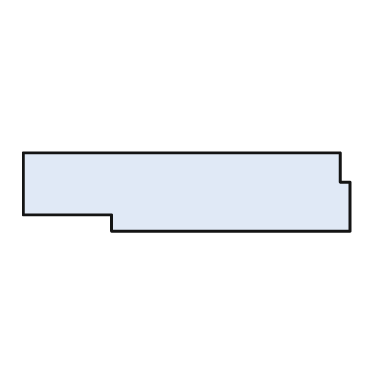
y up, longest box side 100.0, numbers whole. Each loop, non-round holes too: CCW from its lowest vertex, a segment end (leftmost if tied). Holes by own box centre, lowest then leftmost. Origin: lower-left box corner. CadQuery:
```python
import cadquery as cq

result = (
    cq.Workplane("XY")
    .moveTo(27.0, 0.0)
    .lineTo(100.0, 0.0)
    .lineTo(100.0, 15.0)
    .lineTo(97.0, 15.0)
    .lineTo(97.0, 24.0)
    .lineTo(0.0, 24.0)
    .lineTo(0.0, 5.0)
    .lineTo(27.0, 5.0)
    .close()
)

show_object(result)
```